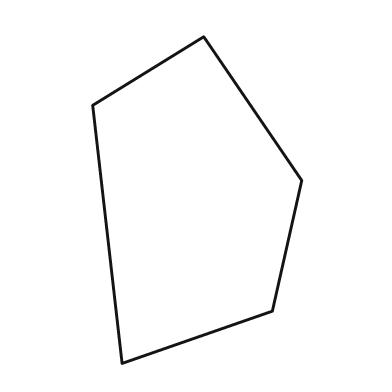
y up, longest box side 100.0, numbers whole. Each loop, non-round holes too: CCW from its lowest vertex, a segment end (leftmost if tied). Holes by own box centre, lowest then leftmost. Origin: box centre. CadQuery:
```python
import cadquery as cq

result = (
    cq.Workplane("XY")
    .moveTo(-23.0, -50.0)
    .lineTo(23.0, -34.0)
    .lineTo(32.0, 6.0)
    .lineTo(2.0, 50.0)
    .lineTo(-32.0, 29.0)
    .close()
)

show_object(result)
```